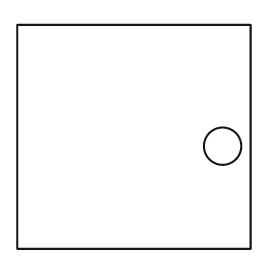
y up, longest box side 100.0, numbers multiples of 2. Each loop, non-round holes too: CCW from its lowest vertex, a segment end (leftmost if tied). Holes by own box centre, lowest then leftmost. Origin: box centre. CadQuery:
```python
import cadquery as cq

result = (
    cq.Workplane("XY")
    .moveTo(-50.0, -48.0)
    .lineTo(50.0, -48.0)
    .lineTo(50.0, 48.0)
    .lineTo(-50.0, 48.0)
    .close()
    .moveTo(38.0, -4.0)
    .circle(8.0)
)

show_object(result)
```